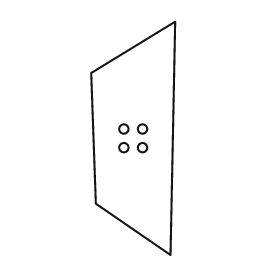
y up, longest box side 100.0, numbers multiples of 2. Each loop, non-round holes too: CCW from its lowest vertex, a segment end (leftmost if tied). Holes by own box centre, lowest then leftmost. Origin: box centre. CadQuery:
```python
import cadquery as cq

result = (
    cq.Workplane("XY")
    .moveTo(16.0, -50.0)
    .lineTo(18.0, 50.0)
    .lineTo(-18.0, 28.0)
    .lineTo(-16.0, -28.0)
    .close()
    .moveTo(-4.0, -4.0)
    .circle(2.0)
    .moveTo(4.0, -4.0)
    .circle(2.0)
    .moveTo(-4.0, 4.0)
    .circle(2.0)
    .moveTo(4.0, 4.0)
    .circle(2.0)
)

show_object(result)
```